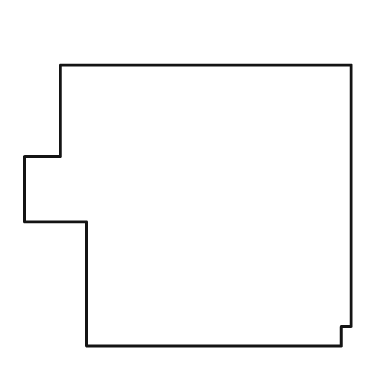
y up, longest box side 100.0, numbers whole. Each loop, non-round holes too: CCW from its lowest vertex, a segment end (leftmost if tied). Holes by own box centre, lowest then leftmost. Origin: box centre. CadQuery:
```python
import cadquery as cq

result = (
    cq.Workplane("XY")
    .moveTo(-31.0, -43.0)
    .lineTo(47.0, -43.0)
    .lineTo(47.0, -37.0)
    .lineTo(50.0, -37.0)
    .lineTo(50.0, 43.0)
    .lineTo(-39.0, 43.0)
    .lineTo(-39.0, 15.0)
    .lineTo(-50.0, 15.0)
    .lineTo(-50.0, -5.0)
    .lineTo(-31.0, -5.0)
    .close()
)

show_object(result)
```